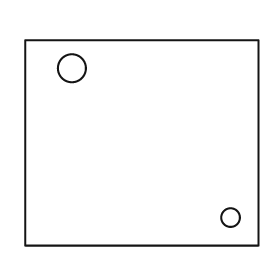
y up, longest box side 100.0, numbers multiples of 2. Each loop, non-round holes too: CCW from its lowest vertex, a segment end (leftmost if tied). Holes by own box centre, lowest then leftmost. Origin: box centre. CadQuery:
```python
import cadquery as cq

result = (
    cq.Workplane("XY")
    .moveTo(-50.0, -44.0)
    .lineTo(50.0, -44.0)
    .lineTo(50.0, 44.0)
    .lineTo(-50.0, 44.0)
    .close()
    .moveTo(38.0, -32.0)
    .circle(4.0)
    .moveTo(-30.0, 32.0)
    .circle(6.0)
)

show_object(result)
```